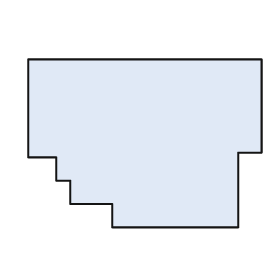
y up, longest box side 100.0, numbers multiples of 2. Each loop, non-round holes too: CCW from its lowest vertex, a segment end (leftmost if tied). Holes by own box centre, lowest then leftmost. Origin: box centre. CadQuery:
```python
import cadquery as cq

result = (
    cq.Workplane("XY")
    .moveTo(-14.0, -36.0)
    .lineTo(40.0, -36.0)
    .lineTo(40.0, -4.0)
    .lineTo(50.0, -4.0)
    .lineTo(50.0, 36.0)
    .lineTo(-50.0, 36.0)
    .lineTo(-50.0, -6.0)
    .lineTo(-38.0, -6.0)
    .lineTo(-38.0, -16.0)
    .lineTo(-32.0, -16.0)
    .lineTo(-32.0, -26.0)
    .lineTo(-14.0, -26.0)
    .close()
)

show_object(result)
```